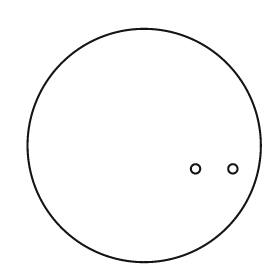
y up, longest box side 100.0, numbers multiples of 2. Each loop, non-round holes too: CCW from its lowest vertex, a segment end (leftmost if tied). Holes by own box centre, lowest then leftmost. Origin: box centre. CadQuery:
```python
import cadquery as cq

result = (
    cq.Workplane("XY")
    .moveTo(0.0, 0.0)
    .circle(50.0)
    .moveTo(22.0, -10.0)
    .circle(2.0)
    .moveTo(38.0, -10.0)
    .circle(2.0)
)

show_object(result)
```